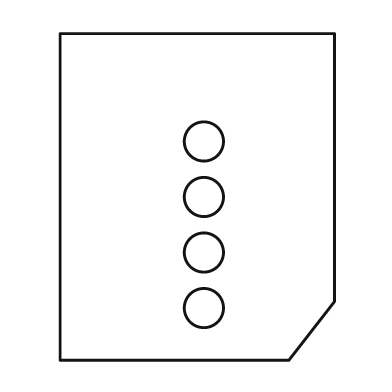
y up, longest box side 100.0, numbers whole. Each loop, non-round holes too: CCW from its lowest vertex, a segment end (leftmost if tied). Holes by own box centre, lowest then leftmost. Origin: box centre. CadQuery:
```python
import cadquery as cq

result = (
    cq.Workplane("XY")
    .moveTo(-42.0, -50.0)
    .lineTo(28.0, -50.0)
    .lineTo(42.0, -32.0)
    .lineTo(42.0, 50.0)
    .lineTo(-42.0, 50.0)
    .close()
    .moveTo(2.0, -34.0)
    .circle(6.0)
    .moveTo(2.0, -17.0)
    .circle(6.0)
    .moveTo(2.0, 0.0)
    .circle(6.0)
    .moveTo(2.0, 17.0)
    .circle(6.0)
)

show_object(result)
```